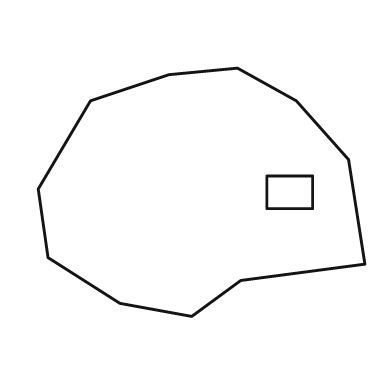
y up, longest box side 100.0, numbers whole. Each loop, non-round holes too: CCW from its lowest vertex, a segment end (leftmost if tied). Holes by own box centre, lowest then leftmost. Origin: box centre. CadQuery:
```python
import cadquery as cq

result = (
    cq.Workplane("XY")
    .moveTo(-3.0, -38.0)
    .lineTo(12.0, -27.0)
    .lineTo(50.0, -22.0)
    .lineTo(45.0, 10.0)
    .lineTo(29.0, 28.0)
    .lineTo(11.0, 38.0)
    .lineTo(-10.0, 36.0)
    .lineTo(-34.0, 28.0)
    .lineTo(-50.0, 1.0)
    .lineTo(-47.0, -20.0)
    .lineTo(-25.0, -34.0)
    .close()
    .moveTo(20.0, -5.0)
    .lineTo(34.0, -5.0)
    .lineTo(34.0, 5.0)
    .lineTo(20.0, 5.0)
    .close()
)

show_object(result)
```